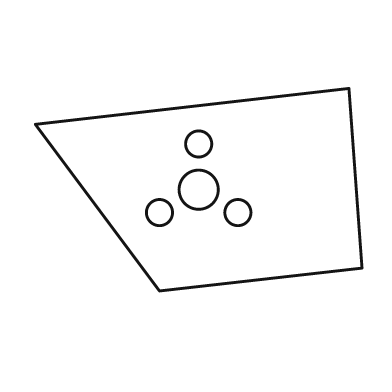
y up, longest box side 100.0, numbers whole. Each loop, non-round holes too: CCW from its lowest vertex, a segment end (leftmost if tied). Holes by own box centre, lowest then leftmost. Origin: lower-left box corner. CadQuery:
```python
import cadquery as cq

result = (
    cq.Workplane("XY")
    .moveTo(38.0, 0.0)
    .lineTo(100.0, 7.0)
    .lineTo(96.0, 62.0)
    .lineTo(0.0, 51.0)
    .close()
    .moveTo(38.0, 24.0)
    .circle(4.0)
    .moveTo(62.0, 24.0)
    .circle(4.0)
    .moveTo(50.0, 31.0)
    .circle(6.0)
    .moveTo(50.0, 45.0)
    .circle(4.0)
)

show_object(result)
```